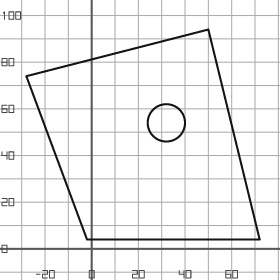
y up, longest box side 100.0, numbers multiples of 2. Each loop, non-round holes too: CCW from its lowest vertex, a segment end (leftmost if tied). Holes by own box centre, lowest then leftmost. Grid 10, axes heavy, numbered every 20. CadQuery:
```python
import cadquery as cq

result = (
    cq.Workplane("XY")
    .moveTo(-2.0, 4.0)
    .lineTo(72.0, 4.0)
    .lineTo(50.0, 94.0)
    .lineTo(-28.0, 74.0)
    .close()
    .moveTo(32.0, 54.0)
    .circle(8.0)
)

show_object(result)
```